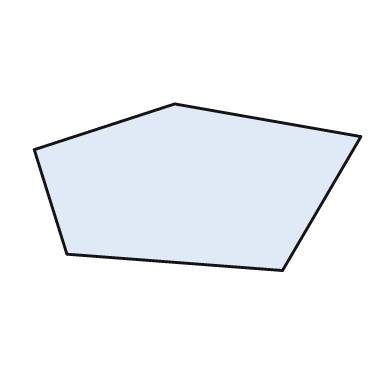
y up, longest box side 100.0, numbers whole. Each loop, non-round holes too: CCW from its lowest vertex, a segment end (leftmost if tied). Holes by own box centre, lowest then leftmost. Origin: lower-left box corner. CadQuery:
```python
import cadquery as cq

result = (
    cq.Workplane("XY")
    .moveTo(76.0, 0.0)
    .lineTo(100.0, 41.0)
    .lineTo(43.0, 51.0)
    .lineTo(0.0, 37.0)
    .lineTo(10.0, 5.0)
    .close()
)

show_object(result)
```